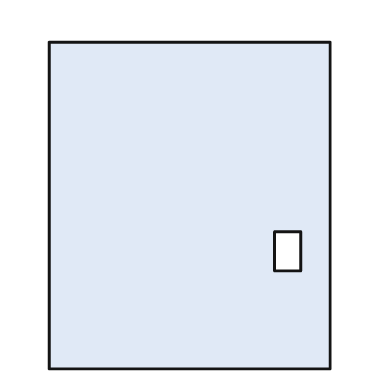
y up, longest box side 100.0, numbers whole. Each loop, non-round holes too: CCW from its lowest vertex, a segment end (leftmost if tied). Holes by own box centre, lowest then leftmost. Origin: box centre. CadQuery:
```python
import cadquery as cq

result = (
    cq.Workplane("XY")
    .moveTo(-43.0, -50.0)
    .lineTo(43.0, -50.0)
    .lineTo(43.0, 50.0)
    .lineTo(-43.0, 50.0)
    .close()
    .moveTo(26.0, -20.0)
    .lineTo(34.0, -20.0)
    .lineTo(34.0, -8.0)
    .lineTo(26.0, -8.0)
    .close()
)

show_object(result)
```